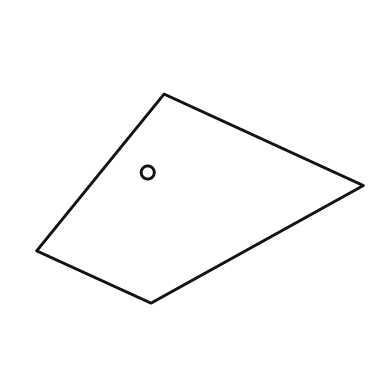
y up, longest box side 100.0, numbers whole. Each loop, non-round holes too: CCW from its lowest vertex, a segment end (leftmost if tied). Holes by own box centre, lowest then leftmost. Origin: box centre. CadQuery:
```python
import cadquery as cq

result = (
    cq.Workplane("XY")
    .moveTo(-15.0, -32.0)
    .lineTo(50.0, 4.0)
    .lineTo(-11.0, 32.0)
    .lineTo(-50.0, -16.0)
    .close()
    .moveTo(-16.0, 8.0)
    .circle(2.0)
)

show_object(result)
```